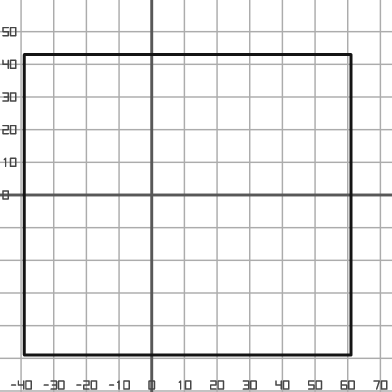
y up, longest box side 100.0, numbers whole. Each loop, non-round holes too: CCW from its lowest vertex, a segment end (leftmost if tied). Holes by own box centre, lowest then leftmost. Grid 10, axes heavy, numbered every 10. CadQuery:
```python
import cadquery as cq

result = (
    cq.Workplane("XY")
    .moveTo(-39.0, -49.0)
    .lineTo(61.0, -49.0)
    .lineTo(61.0, 43.0)
    .lineTo(-39.0, 43.0)
    .close()
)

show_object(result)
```